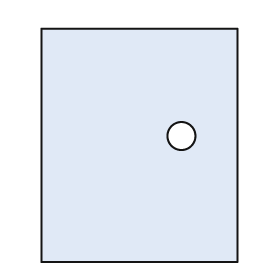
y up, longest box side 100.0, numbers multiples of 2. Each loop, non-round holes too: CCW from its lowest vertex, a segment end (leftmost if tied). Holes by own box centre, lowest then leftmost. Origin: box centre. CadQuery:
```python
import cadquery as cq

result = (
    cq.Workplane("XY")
    .moveTo(-42.0, -50.0)
    .lineTo(42.0, -50.0)
    .lineTo(42.0, 50.0)
    .lineTo(-42.0, 50.0)
    .close()
    .moveTo(18.0, 4.0)
    .circle(6.0)
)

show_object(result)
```